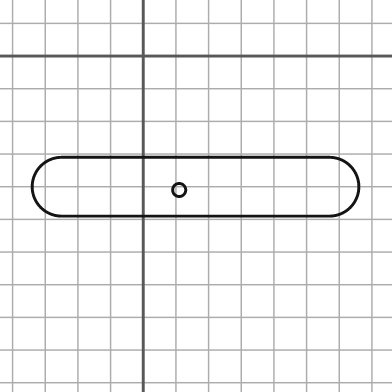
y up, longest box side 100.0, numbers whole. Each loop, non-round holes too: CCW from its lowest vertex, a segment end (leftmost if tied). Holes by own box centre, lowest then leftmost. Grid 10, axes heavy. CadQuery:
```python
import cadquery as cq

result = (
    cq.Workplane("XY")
    .moveTo(-25.0, -49.0)
    .lineTo(57.0, -49.0)
    .threePointArc((66.0, -40.0), (57.0, -31.0))
    .lineTo(-25.0, -31.0)
    .threePointArc((-34.0, -40.0), (-25.0, -49.0))
    .close()
    .moveTo(11.0, -41.0)
    .circle(2.0)
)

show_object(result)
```